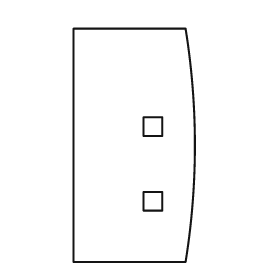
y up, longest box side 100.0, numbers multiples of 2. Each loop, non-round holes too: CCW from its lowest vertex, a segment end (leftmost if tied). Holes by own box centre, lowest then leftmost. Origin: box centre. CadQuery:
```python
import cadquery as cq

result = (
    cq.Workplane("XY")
    .moveTo(-26.0, -50.0)
    .lineTo(22.0, -50.0)
    .threePointArc((26.0, 0.0), (22.0, 50.0))
    .lineTo(-26.0, 50.0)
    .close()
    .moveTo(4.0, -28.0)
    .lineTo(12.0, -28.0)
    .lineTo(12.0, -20.0)
    .lineTo(4.0, -20.0)
    .close()
    .moveTo(4.0, 4.0)
    .lineTo(12.0, 4.0)
    .lineTo(12.0, 12.0)
    .lineTo(4.0, 12.0)
    .close()
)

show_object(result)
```